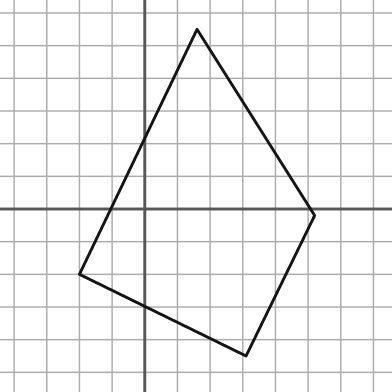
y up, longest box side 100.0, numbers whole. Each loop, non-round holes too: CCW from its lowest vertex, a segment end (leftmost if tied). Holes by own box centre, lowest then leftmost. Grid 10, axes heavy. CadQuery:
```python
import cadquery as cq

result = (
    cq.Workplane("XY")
    .moveTo(31.0, -45.0)
    .lineTo(52.0, -2.0)
    .lineTo(16.0, 55.0)
    .lineTo(-20.0, -20.0)
    .close()
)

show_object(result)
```